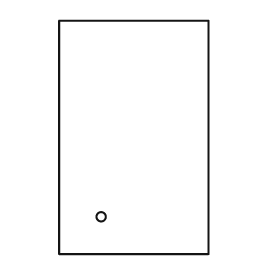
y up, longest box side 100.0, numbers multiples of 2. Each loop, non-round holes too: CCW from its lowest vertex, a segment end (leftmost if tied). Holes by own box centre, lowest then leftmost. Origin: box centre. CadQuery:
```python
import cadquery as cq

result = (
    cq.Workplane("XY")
    .moveTo(-32.0, -50.0)
    .lineTo(32.0, -50.0)
    .lineTo(32.0, 50.0)
    .lineTo(-32.0, 50.0)
    .close()
    .moveTo(-14.0, -34.0)
    .circle(2.0)
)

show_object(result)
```